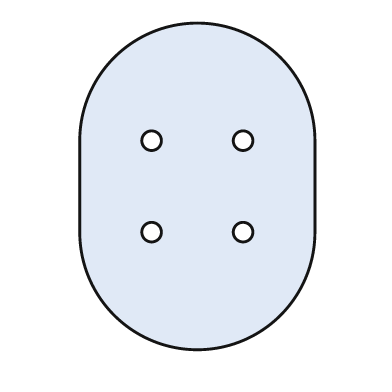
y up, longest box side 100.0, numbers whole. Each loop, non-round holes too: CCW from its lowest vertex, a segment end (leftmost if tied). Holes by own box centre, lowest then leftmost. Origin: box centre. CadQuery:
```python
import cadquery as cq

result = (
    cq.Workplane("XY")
    .moveTo(-36.0, -14.0)
    .threePointArc((0.0, -50.0), (36.0, -14.0))
    .lineTo(36.0, 14.0)
    .threePointArc((0.0, 50.0), (-36.0, 14.0))
    .close()
    .moveTo(-14.0, -14.0)
    .circle(3.0)
    .moveTo(14.0, -14.0)
    .circle(3.0)
    .moveTo(-14.0, 14.0)
    .circle(3.0)
    .moveTo(14.0, 14.0)
    .circle(3.0)
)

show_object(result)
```